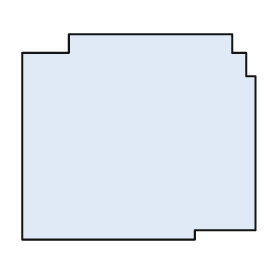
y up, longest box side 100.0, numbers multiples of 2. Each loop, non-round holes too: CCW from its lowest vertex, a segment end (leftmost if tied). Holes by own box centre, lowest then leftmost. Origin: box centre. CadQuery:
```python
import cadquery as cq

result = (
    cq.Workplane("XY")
    .moveTo(-50.0, -44.0)
    .lineTo(24.0, -44.0)
    .lineTo(24.0, -40.0)
    .lineTo(50.0, -40.0)
    .lineTo(50.0, 26.0)
    .lineTo(46.0, 26.0)
    .lineTo(46.0, 36.0)
    .lineTo(40.0, 36.0)
    .lineTo(40.0, 44.0)
    .lineTo(-30.0, 44.0)
    .lineTo(-30.0, 36.0)
    .lineTo(-50.0, 36.0)
    .close()
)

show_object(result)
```